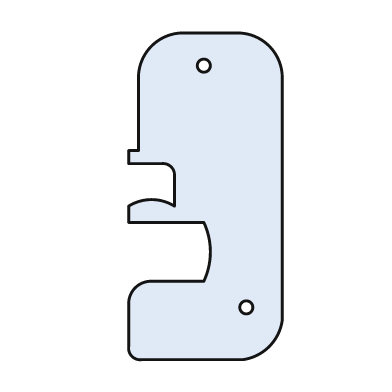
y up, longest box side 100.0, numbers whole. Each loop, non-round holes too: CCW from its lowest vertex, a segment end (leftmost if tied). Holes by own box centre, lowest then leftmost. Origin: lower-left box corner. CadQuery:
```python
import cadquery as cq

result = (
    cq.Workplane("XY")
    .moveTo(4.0, 0.0)
    .lineTo(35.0, 0.0)
    .threePointArc((43.0, 4.0), (47.0, 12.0))
    .lineTo(47.0, 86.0)
    .threePointArc((43.0, 96.0), (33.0, 100.0))
    .lineTo(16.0, 100.0)
    .threePointArc((7.0, 96.0), (3.0, 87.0))
    .lineTo(3.0, 64.0)
    .lineTo(0.0, 64.0)
    .lineTo(0.0, 60.0)
    .lineTo(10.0, 60.0)
    .threePointArc((13.0, 59.0), (14.0, 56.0))
    .lineTo(14.0, 47.0)
    .threePointArc((7.0, 49.0), (0.0, 47.0))
    .lineTo(0.0, 42.0)
    .lineTo(23.0, 42.0)
    .threePointArc((25.0, 33.0), (23.0, 24.0))
    .lineTo(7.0, 24.0)
    .threePointArc((2.0, 22.0), (0.0, 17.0))
    .lineTo(0.0, 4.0)
    .threePointArc((1.0, 1.0), (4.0, 0.0))
    .close()
    .moveTo(36.0, 16.0)
    .circle(2.0)
    .moveTo(23.0, 90.0)
    .circle(2.0)
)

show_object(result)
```